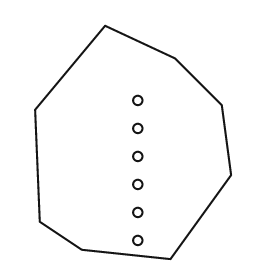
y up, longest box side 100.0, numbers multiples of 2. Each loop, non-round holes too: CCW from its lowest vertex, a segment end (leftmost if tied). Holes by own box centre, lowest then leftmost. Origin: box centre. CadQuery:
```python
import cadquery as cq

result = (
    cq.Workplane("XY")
    .moveTo(16.0, -50.0)
    .lineTo(42.0, -14.0)
    .lineTo(38.0, 16.0)
    .lineTo(18.0, 36.0)
    .lineTo(-12.0, 50.0)
    .lineTo(-42.0, 14.0)
    .lineTo(-40.0, -34.0)
    .lineTo(-22.0, -46.0)
    .close()
    .moveTo(2.0, -42.0)
    .circle(2.0)
    .moveTo(2.0, -30.0)
    .circle(2.0)
    .moveTo(2.0, -18.0)
    .circle(2.0)
    .moveTo(2.0, -6.0)
    .circle(2.0)
    .moveTo(2.0, 6.0)
    .circle(2.0)
    .moveTo(2.0, 18.0)
    .circle(2.0)
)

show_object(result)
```